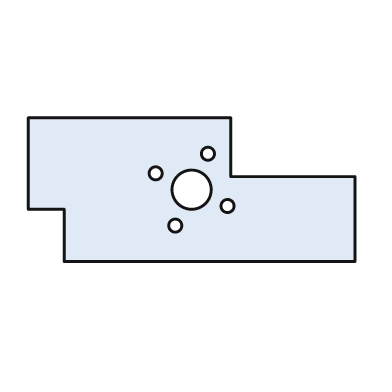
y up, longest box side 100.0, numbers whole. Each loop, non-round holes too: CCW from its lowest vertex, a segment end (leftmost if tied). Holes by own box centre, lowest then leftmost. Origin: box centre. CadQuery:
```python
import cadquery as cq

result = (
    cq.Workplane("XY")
    .moveTo(-39.0, -22.0)
    .lineTo(50.0, -22.0)
    .lineTo(50.0, 4.0)
    .lineTo(12.0, 4.0)
    .lineTo(12.0, 22.0)
    .lineTo(-50.0, 22.0)
    .lineTo(-50.0, -6.0)
    .lineTo(-39.0, -6.0)
    .close()
    .moveTo(-5.0, -11.0)
    .circle(2.0)
    .moveTo(11.0, -5.0)
    .circle(2.0)
    .moveTo(0.0, 0.0)
    .circle(6.0)
    .moveTo(-11.0, 5.0)
    .circle(2.0)
    .moveTo(5.0, 11.0)
    .circle(2.0)
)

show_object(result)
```